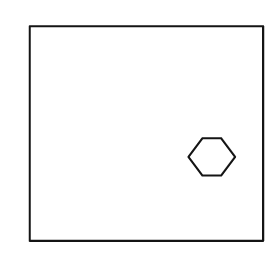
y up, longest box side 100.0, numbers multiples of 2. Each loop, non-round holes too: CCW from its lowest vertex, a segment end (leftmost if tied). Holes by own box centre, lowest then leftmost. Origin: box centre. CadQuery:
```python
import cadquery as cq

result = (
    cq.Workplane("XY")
    .moveTo(-50.0, -46.0)
    .lineTo(50.0, -46.0)
    .lineTo(50.0, 46.0)
    .lineTo(-50.0, 46.0)
    .close()
    .moveTo(24.0, -18.0)
    .lineTo(32.0, -18.0)
    .lineTo(38.0, -10.0)
    .lineTo(32.0, -2.0)
    .lineTo(24.0, -2.0)
    .lineTo(18.0, -10.0)
    .close()
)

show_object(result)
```